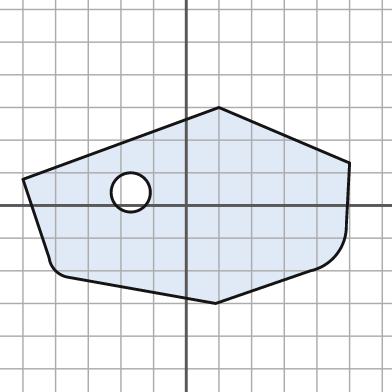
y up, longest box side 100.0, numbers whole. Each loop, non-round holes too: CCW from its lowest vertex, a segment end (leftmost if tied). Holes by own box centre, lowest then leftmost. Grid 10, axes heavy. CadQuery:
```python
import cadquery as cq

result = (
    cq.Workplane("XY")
    .moveTo(9.0, -30.0)
    .lineTo(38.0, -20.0)
    .threePointArc((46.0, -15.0), (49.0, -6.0))
    .lineTo(50.0, 13.0)
    .lineTo(10.0, 30.0)
    .lineTo(-50.0, 8.0)
    .lineTo(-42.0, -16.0)
    .threePointArc((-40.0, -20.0), (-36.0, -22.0))
    .close()
    .moveTo(-17.0, 4.0)
    .circle(6.0)
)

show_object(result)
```